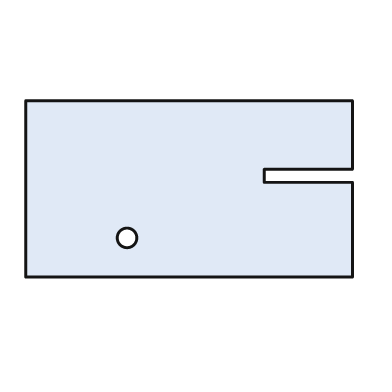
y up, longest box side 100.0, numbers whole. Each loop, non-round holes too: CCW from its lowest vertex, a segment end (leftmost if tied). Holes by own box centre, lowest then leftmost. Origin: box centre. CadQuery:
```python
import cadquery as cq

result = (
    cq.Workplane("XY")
    .moveTo(-50.0, -27.0)
    .lineTo(50.0, -27.0)
    .lineTo(50.0, 2.0)
    .lineTo(23.0, 2.0)
    .lineTo(23.0, 6.0)
    .lineTo(50.0, 6.0)
    .lineTo(50.0, 27.0)
    .lineTo(-50.0, 27.0)
    .close()
    .moveTo(-19.0, -15.0)
    .circle(3.0)
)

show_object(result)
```